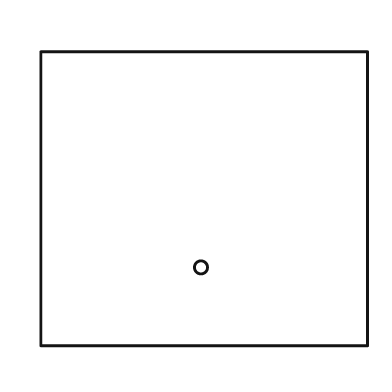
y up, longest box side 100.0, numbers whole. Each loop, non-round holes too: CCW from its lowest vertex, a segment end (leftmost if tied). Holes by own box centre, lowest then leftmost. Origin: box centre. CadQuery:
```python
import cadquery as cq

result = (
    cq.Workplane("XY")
    .moveTo(-50.0, -45.0)
    .lineTo(50.0, -45.0)
    .lineTo(50.0, 45.0)
    .lineTo(-50.0, 45.0)
    .close()
    .moveTo(-1.0, -21.0)
    .circle(2.0)
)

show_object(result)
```